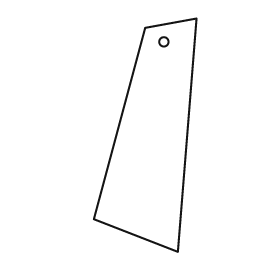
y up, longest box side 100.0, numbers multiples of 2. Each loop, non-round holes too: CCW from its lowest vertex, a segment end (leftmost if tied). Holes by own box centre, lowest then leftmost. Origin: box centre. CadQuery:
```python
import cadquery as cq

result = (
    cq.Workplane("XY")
    .moveTo(14.0, -50.0)
    .lineTo(22.0, 50.0)
    .lineTo(0.0, 46.0)
    .lineTo(-22.0, -36.0)
    .close()
    .moveTo(8.0, 40.0)
    .circle(2.0)
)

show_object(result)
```